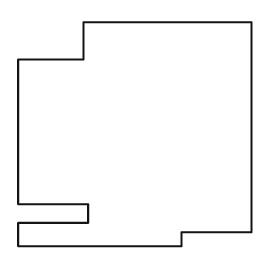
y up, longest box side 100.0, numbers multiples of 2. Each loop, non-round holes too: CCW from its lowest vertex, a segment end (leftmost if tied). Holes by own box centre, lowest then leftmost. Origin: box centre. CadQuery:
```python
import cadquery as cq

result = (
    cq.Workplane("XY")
    .moveTo(-50.0, -48.0)
    .lineTo(20.0, -48.0)
    .lineTo(20.0, -42.0)
    .lineTo(50.0, -42.0)
    .lineTo(50.0, 48.0)
    .lineTo(-22.0, 48.0)
    .lineTo(-22.0, 32.0)
    .lineTo(-50.0, 32.0)
    .lineTo(-50.0, -30.0)
    .lineTo(-20.0, -30.0)
    .lineTo(-20.0, -38.0)
    .lineTo(-50.0, -38.0)
    .close()
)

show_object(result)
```